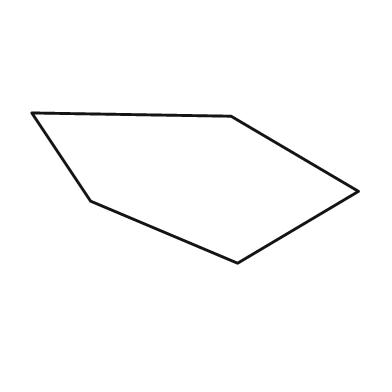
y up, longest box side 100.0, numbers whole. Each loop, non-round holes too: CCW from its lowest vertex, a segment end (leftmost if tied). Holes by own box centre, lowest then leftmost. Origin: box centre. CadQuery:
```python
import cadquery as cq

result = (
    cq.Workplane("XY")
    .moveTo(13.0, -23.0)
    .lineTo(50.0, -1.0)
    .lineTo(11.0, 22.0)
    .lineTo(-50.0, 23.0)
    .lineTo(-32.0, -4.0)
    .close()
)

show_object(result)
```